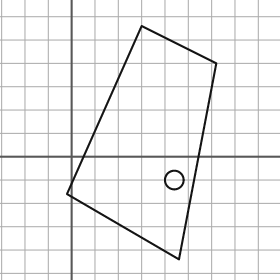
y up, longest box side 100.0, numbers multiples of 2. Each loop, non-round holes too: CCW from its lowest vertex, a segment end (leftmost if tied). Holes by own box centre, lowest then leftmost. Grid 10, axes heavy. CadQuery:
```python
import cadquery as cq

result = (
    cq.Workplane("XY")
    .moveTo(46.0, -44.0)
    .lineTo(62.0, 40.0)
    .lineTo(30.0, 56.0)
    .lineTo(-2.0, -16.0)
    .close()
    .moveTo(44.0, -10.0)
    .circle(4.0)
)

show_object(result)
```